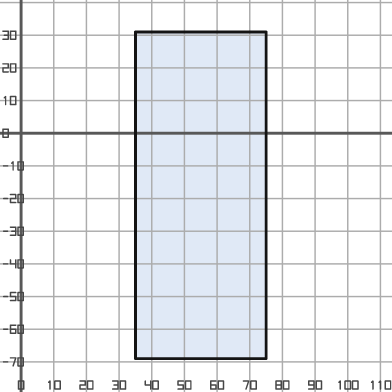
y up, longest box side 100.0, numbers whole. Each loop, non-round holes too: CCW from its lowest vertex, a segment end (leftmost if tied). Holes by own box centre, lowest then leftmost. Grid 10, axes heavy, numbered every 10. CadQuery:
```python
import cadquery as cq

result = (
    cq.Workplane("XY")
    .moveTo(35.0, -69.0)
    .lineTo(75.0, -69.0)
    .lineTo(75.0, 31.0)
    .lineTo(35.0, 31.0)
    .close()
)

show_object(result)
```